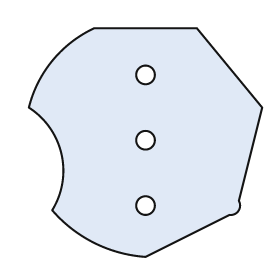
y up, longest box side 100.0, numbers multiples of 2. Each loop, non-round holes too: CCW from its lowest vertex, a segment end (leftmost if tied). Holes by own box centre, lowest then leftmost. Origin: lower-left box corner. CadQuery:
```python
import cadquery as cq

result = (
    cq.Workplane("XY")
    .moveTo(50.0, 0.0)
    .lineTo(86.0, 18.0)
    .threePointArc((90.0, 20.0), (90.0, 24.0))
    .lineTo(100.0, 64.0)
    .lineTo(72.0, 98.0)
    .lineTo(28.0, 98.0)
    .threePointArc((10.0, 84.0), (0.0, 64.0))
    .threePointArc((14.0, 44.0), (10.0, 20.0))
    .threePointArc((28.0, 6.0), (50.0, 0.0))
    .close()
    .moveTo(50.0, 22.0)
    .circle(4.0)
    .moveTo(50.0, 50.0)
    .circle(4.0)
    .moveTo(50.0, 78.0)
    .circle(4.0)
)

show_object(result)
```